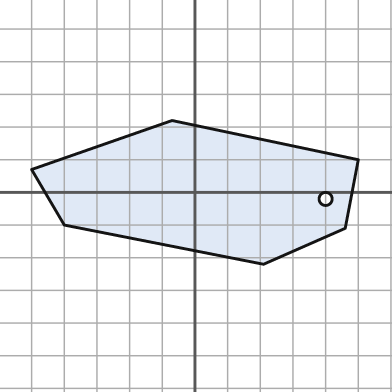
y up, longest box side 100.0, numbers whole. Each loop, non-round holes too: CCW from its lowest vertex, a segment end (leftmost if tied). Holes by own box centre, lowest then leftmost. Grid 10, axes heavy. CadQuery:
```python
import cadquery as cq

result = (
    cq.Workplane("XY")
    .moveTo(21.0, -22.0)
    .lineTo(46.0, -11.0)
    .lineTo(50.0, 10.0)
    .lineTo(-7.0, 22.0)
    .lineTo(-50.0, 7.0)
    .lineTo(-40.0, -10.0)
    .close()
    .moveTo(40.0, -2.0)
    .circle(2.0)
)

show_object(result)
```